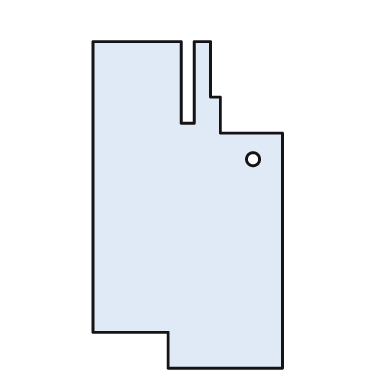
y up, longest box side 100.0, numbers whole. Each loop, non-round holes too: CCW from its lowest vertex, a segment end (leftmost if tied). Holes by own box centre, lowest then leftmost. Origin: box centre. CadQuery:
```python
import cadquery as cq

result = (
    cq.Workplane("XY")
    .moveTo(-6.0, -50.0)
    .lineTo(29.0, -50.0)
    .lineTo(29.0, 22.0)
    .lineTo(10.0, 22.0)
    .lineTo(10.0, 33.0)
    .lineTo(7.0, 33.0)
    .lineTo(7.0, 50.0)
    .lineTo(2.0, 50.0)
    .lineTo(2.0, 25.0)
    .lineTo(-2.0, 25.0)
    .lineTo(-2.0, 50.0)
    .lineTo(-29.0, 50.0)
    .lineTo(-29.0, -39.0)
    .lineTo(-6.0, -39.0)
    .close()
    .moveTo(20.0, 14.0)
    .circle(2.0)
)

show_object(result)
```